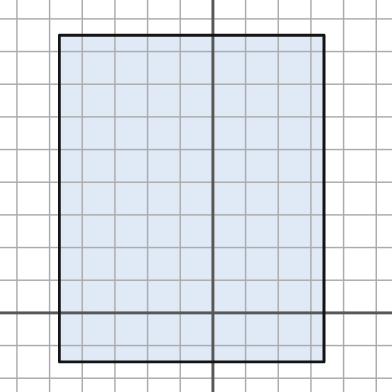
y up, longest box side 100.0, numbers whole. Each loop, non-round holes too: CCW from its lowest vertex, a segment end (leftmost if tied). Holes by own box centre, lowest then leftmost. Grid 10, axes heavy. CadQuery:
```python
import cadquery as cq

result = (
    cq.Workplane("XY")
    .moveTo(-47.0, -15.0)
    .lineTo(34.0, -15.0)
    .lineTo(34.0, 85.0)
    .lineTo(-47.0, 85.0)
    .close()
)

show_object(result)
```